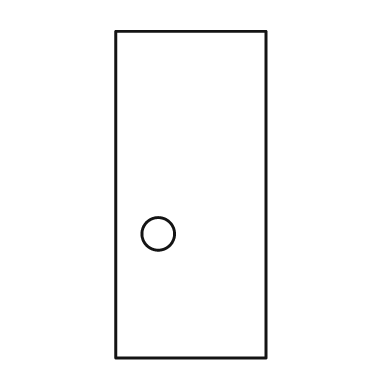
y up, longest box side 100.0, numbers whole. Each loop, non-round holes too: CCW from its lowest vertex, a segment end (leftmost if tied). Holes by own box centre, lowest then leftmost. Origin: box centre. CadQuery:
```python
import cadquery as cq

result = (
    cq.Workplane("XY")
    .moveTo(-23.0, -50.0)
    .lineTo(23.0, -50.0)
    .lineTo(23.0, 50.0)
    .lineTo(-23.0, 50.0)
    .close()
    .moveTo(-10.0, -12.0)
    .circle(5.0)
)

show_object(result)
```